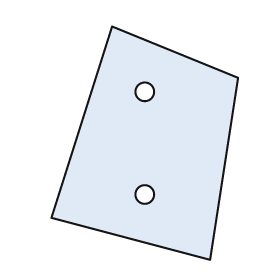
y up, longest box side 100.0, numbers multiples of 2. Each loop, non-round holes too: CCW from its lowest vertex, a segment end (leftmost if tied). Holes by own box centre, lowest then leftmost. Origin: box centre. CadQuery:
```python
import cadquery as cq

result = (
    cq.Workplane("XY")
    .moveTo(28.0, -50.0)
    .lineTo(40.0, 28.0)
    .lineTo(-14.0, 50.0)
    .lineTo(-40.0, -32.0)
    .close()
    .moveTo(0.0, -22.0)
    .circle(4.0)
    .moveTo(0.0, 22.0)
    .circle(4.0)
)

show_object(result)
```